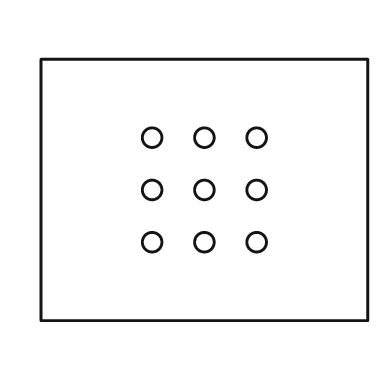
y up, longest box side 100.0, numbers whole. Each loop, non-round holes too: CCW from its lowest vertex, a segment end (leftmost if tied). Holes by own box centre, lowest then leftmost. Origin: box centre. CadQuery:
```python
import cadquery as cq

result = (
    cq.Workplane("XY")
    .moveTo(-50.0, -40.0)
    .lineTo(50.0, -40.0)
    .lineTo(50.0, 40.0)
    .lineTo(-50.0, 40.0)
    .close()
    .moveTo(-16.0, -16.0)
    .circle(3.0)
    .moveTo(0.0, -16.0)
    .circle(3.0)
    .moveTo(16.0, -16.0)
    .circle(3.0)
    .moveTo(-16.0, 0.0)
    .circle(3.0)
    .moveTo(0.0, 0.0)
    .circle(3.0)
    .moveTo(16.0, 0.0)
    .circle(3.0)
    .moveTo(-16.0, 16.0)
    .circle(3.0)
    .moveTo(0.0, 16.0)
    .circle(3.0)
    .moveTo(16.0, 16.0)
    .circle(3.0)
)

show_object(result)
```